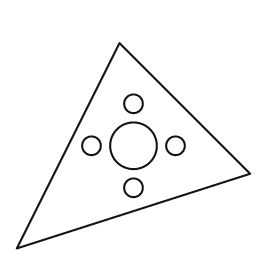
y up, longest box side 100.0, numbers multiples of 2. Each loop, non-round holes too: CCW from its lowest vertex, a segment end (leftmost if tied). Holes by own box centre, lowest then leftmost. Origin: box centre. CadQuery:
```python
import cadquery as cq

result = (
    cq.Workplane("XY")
    .moveTo(-50.0, -44.0)
    .lineTo(50.0, -12.0)
    .lineTo(-6.0, 44.0)
    .close()
    .moveTo(0.0, -18.0)
    .circle(4.0)
    .moveTo(-18.0, 0.0)
    .circle(4.0)
    .moveTo(0.0, 0.0)
    .circle(10.0)
    .moveTo(18.0, 0.0)
    .circle(4.0)
    .moveTo(0.0, 18.0)
    .circle(4.0)
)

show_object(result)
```